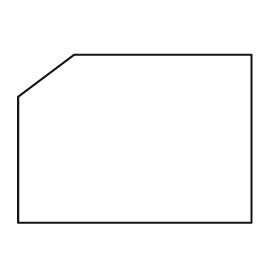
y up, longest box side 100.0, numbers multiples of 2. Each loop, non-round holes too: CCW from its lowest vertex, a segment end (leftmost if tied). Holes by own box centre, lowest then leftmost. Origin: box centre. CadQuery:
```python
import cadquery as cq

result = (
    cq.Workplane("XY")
    .moveTo(-50.0, -36.0)
    .lineTo(50.0, -36.0)
    .lineTo(50.0, 36.0)
    .lineTo(-26.0, 36.0)
    .lineTo(-50.0, 18.0)
    .close()
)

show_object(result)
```